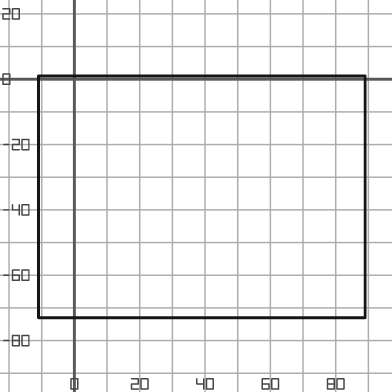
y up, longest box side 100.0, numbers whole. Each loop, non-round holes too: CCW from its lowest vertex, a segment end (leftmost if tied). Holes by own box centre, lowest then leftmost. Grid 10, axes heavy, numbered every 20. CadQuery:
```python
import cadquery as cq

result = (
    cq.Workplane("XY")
    .moveTo(-11.0, -73.0)
    .lineTo(89.0, -73.0)
    .lineTo(89.0, 1.0)
    .lineTo(-11.0, 1.0)
    .close()
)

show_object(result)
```